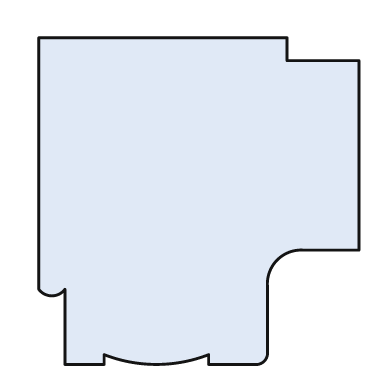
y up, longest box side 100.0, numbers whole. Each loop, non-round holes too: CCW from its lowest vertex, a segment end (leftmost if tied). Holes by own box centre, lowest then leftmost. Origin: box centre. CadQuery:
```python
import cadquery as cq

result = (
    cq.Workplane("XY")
    .moveTo(-41.0, -50.0)
    .lineTo(-29.0, -50.0)
    .lineTo(-29.0, -47.0)
    .threePointArc((-13.0, -50.0), (3.0, -47.0))
    .lineTo(3.0, -50.0)
    .lineTo(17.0, -50.0)
    .threePointArc((20.0, -49.0), (21.0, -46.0))
    .lineTo(21.0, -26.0)
    .threePointArc((24.0, -18.0), (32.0, -15.0))
    .lineTo(49.0, -15.0)
    .lineTo(49.0, 43.0)
    .lineTo(27.0, 43.0)
    .lineTo(27.0, 50.0)
    .lineTo(-49.0, 50.0)
    .lineTo(-49.0, -27.0)
    .threePointArc((-45.0, -29.0), (-41.0, -27.0))
    .close()
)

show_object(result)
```